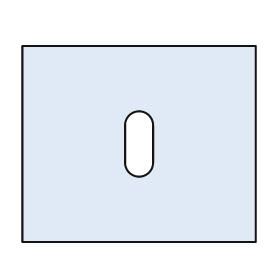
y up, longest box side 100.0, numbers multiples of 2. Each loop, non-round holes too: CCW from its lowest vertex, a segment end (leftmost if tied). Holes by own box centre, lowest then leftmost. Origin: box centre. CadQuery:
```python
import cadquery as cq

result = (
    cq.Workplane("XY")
    .moveTo(-50.0, -42.0)
    .lineTo(50.0, -42.0)
    .lineTo(50.0, 42.0)
    .lineTo(-50.0, 42.0)
    .close()
    .moveTo(-6.0, -8.0)
    .threePointArc((0.0, -14.0), (6.0, -8.0))
    .lineTo(6.0, 8.0)
    .threePointArc((0.0, 14.0), (-6.0, 8.0))
    .close()
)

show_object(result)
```